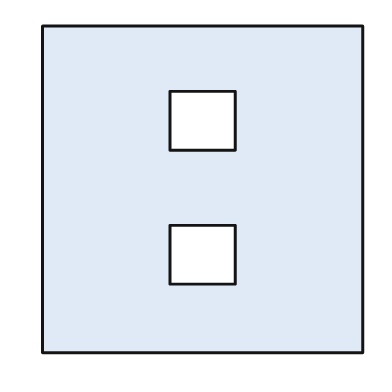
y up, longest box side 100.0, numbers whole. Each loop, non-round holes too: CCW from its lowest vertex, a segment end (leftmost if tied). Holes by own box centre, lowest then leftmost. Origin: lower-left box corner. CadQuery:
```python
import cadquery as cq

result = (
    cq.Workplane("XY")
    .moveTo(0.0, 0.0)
    .lineTo(98.0, 0.0)
    .lineTo(98.0, 100.0)
    .lineTo(0.0, 100.0)
    .close()
    .moveTo(39.0, 21.0)
    .lineTo(59.0, 21.0)
    .lineTo(59.0, 39.0)
    .lineTo(39.0, 39.0)
    .close()
    .moveTo(39.0, 62.0)
    .lineTo(59.0, 62.0)
    .lineTo(59.0, 80.0)
    .lineTo(39.0, 80.0)
    .close()
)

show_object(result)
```